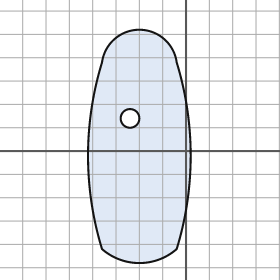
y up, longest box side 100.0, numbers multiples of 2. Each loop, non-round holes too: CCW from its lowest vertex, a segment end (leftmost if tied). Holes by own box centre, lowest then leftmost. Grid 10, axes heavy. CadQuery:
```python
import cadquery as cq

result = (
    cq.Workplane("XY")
    .moveTo(-36.0, -42.0)
    .threePointArc((-20.0, -48.0), (-4.0, -42.0))
    .threePointArc((2.0, -2.0), (-4.0, 38.0))
    .threePointArc((-20.0, 52.0), (-36.0, 38.0))
    .threePointArc((-42.0, -2.0), (-36.0, -42.0))
    .close()
    .moveTo(-24.0, 14.0)
    .circle(4.0)
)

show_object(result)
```